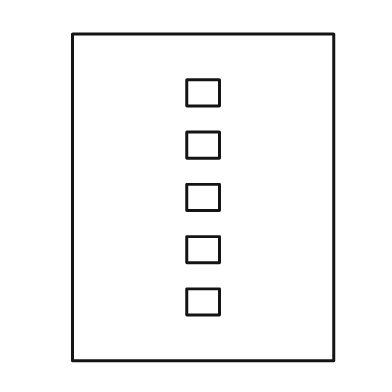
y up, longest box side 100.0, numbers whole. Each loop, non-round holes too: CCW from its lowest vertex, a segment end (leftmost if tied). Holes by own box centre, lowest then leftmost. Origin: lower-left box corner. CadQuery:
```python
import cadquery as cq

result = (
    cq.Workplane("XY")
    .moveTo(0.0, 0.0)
    .lineTo(80.0, 0.0)
    .lineTo(80.0, 100.0)
    .lineTo(0.0, 100.0)
    .close()
    .moveTo(35.0, 14.0)
    .lineTo(45.0, 14.0)
    .lineTo(45.0, 22.0)
    .lineTo(35.0, 22.0)
    .close()
    .moveTo(35.0, 30.0)
    .lineTo(45.0, 30.0)
    .lineTo(45.0, 38.0)
    .lineTo(35.0, 38.0)
    .close()
    .moveTo(35.0, 46.0)
    .lineTo(45.0, 46.0)
    .lineTo(45.0, 54.0)
    .lineTo(35.0, 54.0)
    .close()
    .moveTo(35.0, 62.0)
    .lineTo(45.0, 62.0)
    .lineTo(45.0, 70.0)
    .lineTo(35.0, 70.0)
    .close()
    .moveTo(35.0, 78.0)
    .lineTo(45.0, 78.0)
    .lineTo(45.0, 86.0)
    .lineTo(35.0, 86.0)
    .close()
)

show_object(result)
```